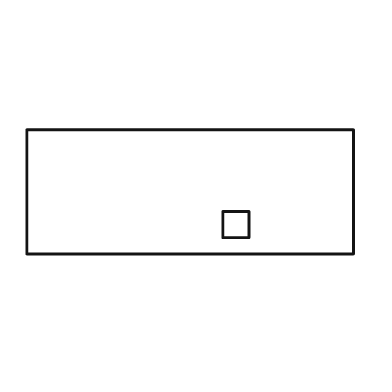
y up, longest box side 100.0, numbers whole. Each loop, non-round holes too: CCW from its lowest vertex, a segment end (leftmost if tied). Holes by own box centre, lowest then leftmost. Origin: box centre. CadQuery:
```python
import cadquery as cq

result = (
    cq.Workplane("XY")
    .moveTo(-50.0, -19.0)
    .lineTo(50.0, -19.0)
    .lineTo(50.0, 19.0)
    .lineTo(-50.0, 19.0)
    .close()
    .moveTo(10.0, -14.0)
    .lineTo(18.0, -14.0)
    .lineTo(18.0, -6.0)
    .lineTo(10.0, -6.0)
    .close()
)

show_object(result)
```